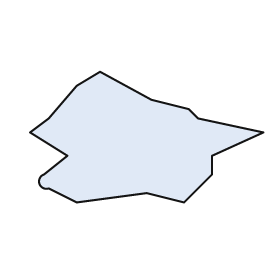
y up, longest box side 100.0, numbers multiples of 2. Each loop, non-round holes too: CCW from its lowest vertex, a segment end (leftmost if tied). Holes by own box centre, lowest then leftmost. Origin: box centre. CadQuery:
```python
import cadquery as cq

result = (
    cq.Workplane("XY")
    .moveTo(-30.0, -28.0)
    .lineTo(0.0, -24.0)
    .lineTo(16.0, -28.0)
    .lineTo(28.0, -16.0)
    .lineTo(28.0, -8.0)
    .lineTo(50.0, 2.0)
    .lineTo(22.0, 8.0)
    .lineTo(18.0, 12.0)
    .lineTo(2.0, 16.0)
    .lineTo(-20.0, 28.0)
    .lineTo(-30.0, 22.0)
    .lineTo(-42.0, 8.0)
    .lineTo(-50.0, 2.0)
    .lineTo(-34.0, -8.0)
    .lineTo(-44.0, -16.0)
    .threePointArc((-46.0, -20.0), (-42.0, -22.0))
    .close()
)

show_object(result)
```